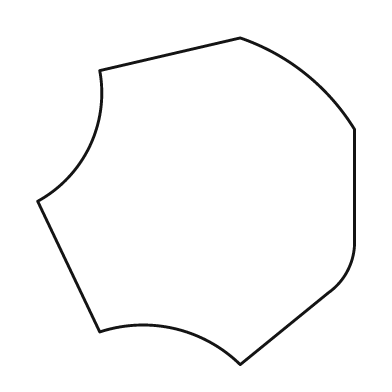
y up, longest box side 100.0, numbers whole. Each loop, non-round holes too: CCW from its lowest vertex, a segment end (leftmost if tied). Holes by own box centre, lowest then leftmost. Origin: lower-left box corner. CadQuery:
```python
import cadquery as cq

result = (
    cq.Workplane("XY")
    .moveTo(62.0, 0.0)
    .lineTo(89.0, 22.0)
    .threePointArc((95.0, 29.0), (97.0, 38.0))
    .lineTo(97.0, 72.0)
    .threePointArc((82.0, 89.0), (62.0, 100.0))
    .lineTo(19.0, 90.0)
    .threePointArc((16.0, 67.0), (0.0, 50.0))
    .lineTo(19.0, 10.0)
    .threePointArc((42.0, 11.0), (62.0, 0.0))
    .close()
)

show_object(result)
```